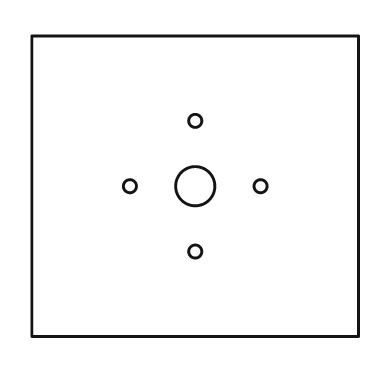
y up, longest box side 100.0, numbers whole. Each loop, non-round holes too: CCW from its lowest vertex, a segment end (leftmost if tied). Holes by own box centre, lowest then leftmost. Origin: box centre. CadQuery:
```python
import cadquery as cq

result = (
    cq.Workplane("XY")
    .moveTo(-50.0, -46.0)
    .lineTo(50.0, -46.0)
    .lineTo(50.0, 46.0)
    .lineTo(-50.0, 46.0)
    .close()
    .moveTo(0.0, -20.0)
    .circle(2.0)
    .moveTo(-20.0, 0.0)
    .circle(2.0)
    .moveTo(0.0, 0.0)
    .circle(6.0)
    .moveTo(20.0, 0.0)
    .circle(2.0)
    .moveTo(0.0, 20.0)
    .circle(2.0)
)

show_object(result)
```